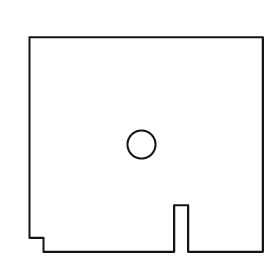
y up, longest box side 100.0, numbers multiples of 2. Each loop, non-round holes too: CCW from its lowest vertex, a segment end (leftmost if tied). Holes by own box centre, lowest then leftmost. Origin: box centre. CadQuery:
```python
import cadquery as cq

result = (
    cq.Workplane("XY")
    .moveTo(-44.0, -46.0)
    .lineTo(12.0, -46.0)
    .lineTo(12.0, -26.0)
    .lineTo(18.0, -26.0)
    .lineTo(18.0, -46.0)
    .lineTo(50.0, -46.0)
    .lineTo(50.0, 46.0)
    .lineTo(-50.0, 46.0)
    .lineTo(-50.0, -40.0)
    .lineTo(-44.0, -40.0)
    .close()
    .moveTo(-2.0, 0.0)
    .circle(6.0)
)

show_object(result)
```